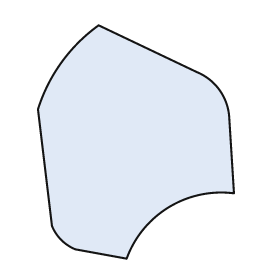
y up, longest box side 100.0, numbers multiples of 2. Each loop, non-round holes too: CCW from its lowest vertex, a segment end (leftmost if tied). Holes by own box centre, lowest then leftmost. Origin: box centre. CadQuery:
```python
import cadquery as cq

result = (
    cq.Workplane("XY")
    .moveTo(-4.0, -50.0)
    .threePointArc((14.0, -28.0), (42.0, -22.0))
    .lineTo(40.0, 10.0)
    .threePointArc((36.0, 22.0), (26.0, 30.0))
    .lineTo(-16.0, 50.0)
    .threePointArc((-32.0, 34.0), (-42.0, 14.0))
    .lineTo(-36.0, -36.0)
    .threePointArc((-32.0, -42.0), (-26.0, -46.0))
    .close()
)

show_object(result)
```